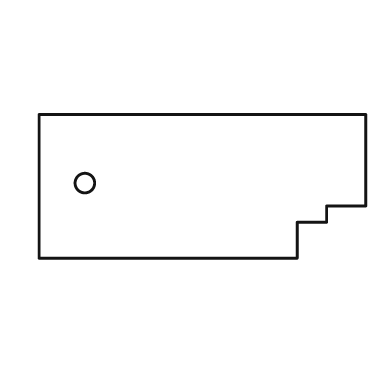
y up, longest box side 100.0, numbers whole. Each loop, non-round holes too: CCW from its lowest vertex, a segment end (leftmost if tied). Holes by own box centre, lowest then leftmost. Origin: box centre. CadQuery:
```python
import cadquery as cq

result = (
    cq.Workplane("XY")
    .moveTo(-50.0, -22.0)
    .lineTo(29.0, -22.0)
    .lineTo(29.0, -11.0)
    .lineTo(38.0, -11.0)
    .lineTo(38.0, -6.0)
    .lineTo(50.0, -6.0)
    .lineTo(50.0, 22.0)
    .lineTo(-50.0, 22.0)
    .close()
    .moveTo(-36.0, 1.0)
    .circle(3.0)
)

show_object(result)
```